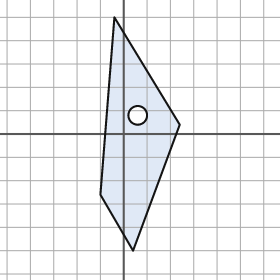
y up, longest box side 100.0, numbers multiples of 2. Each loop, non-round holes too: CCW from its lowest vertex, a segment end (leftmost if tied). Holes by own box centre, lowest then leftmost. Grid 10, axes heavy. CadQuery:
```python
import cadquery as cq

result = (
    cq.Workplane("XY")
    .moveTo(4.0, -50.0)
    .lineTo(24.0, 4.0)
    .lineTo(-4.0, 50.0)
    .lineTo(-10.0, -26.0)
    .close()
    .moveTo(6.0, 8.0)
    .circle(4.0)
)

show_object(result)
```